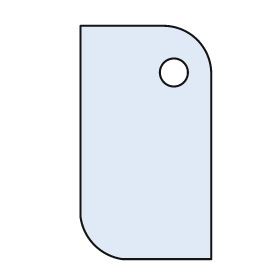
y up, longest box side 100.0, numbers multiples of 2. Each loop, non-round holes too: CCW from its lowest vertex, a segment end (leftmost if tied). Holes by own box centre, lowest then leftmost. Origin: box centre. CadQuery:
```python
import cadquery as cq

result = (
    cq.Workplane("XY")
    .moveTo(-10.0, -50.0)
    .lineTo(28.0, -50.0)
    .lineTo(28.0, 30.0)
    .threePointArc((22.0, 44.0), (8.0, 50.0))
    .lineTo(-28.0, 50.0)
    .lineTo(-28.0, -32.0)
    .threePointArc((-22.0, -44.0), (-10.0, -50.0))
    .close()
    .moveTo(12.0, 30.0)
    .circle(6.0)
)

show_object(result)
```